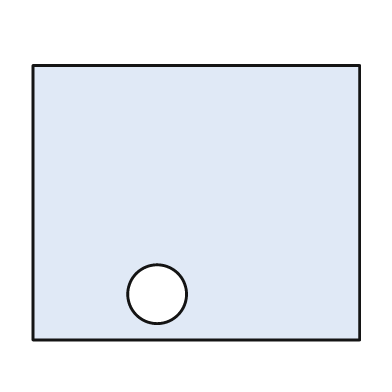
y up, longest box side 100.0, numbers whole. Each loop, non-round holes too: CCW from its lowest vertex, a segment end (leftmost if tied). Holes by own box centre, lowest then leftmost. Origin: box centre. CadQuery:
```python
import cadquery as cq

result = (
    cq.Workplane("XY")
    .moveTo(-50.0, -42.0)
    .lineTo(50.0, -42.0)
    .lineTo(50.0, 42.0)
    .lineTo(-50.0, 42.0)
    .close()
    .moveTo(-12.0, -28.0)
    .circle(9.0)
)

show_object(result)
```